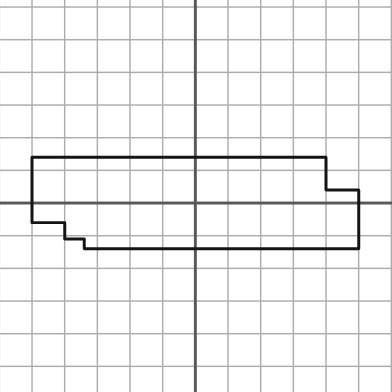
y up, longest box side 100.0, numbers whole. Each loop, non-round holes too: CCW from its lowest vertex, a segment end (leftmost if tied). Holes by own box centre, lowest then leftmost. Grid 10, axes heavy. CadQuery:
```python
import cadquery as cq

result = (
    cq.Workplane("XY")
    .moveTo(-34.0, -14.0)
    .lineTo(50.0, -14.0)
    .lineTo(50.0, 4.0)
    .lineTo(40.0, 4.0)
    .lineTo(40.0, 14.0)
    .lineTo(-50.0, 14.0)
    .lineTo(-50.0, -6.0)
    .lineTo(-40.0, -6.0)
    .lineTo(-40.0, -11.0)
    .lineTo(-34.0, -11.0)
    .close()
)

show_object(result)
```